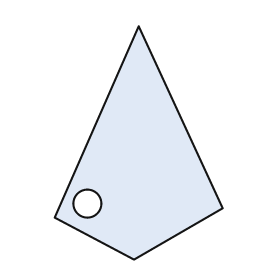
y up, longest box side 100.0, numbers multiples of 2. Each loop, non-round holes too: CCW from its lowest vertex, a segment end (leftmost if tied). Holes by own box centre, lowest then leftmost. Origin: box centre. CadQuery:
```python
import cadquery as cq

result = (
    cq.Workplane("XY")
    .moveTo(-2.0, -50.0)
    .lineTo(36.0, -28.0)
    .lineTo(0.0, 50.0)
    .lineTo(-36.0, -32.0)
    .close()
    .moveTo(-22.0, -26.0)
    .circle(6.0)
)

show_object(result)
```